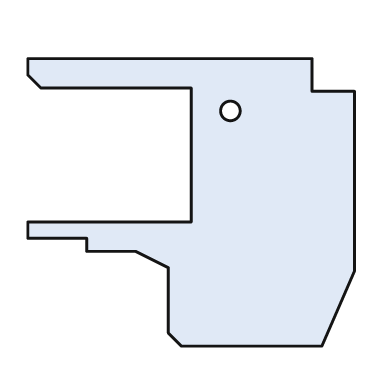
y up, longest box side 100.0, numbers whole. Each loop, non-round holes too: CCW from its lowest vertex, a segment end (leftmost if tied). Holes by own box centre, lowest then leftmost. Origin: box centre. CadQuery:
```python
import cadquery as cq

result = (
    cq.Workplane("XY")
    .moveTo(-3.0, -44.0)
    .lineTo(40.0, -44.0)
    .lineTo(50.0, -21.0)
    .lineTo(50.0, 34.0)
    .lineTo(37.0, 34.0)
    .lineTo(37.0, 44.0)
    .lineTo(-50.0, 44.0)
    .lineTo(-50.0, 39.0)
    .lineTo(-46.0, 35.0)
    .lineTo(0.0, 35.0)
    .lineTo(0.0, -6.0)
    .lineTo(-50.0, -6.0)
    .lineTo(-50.0, -11.0)
    .lineTo(-32.0, -11.0)
    .lineTo(-32.0, -15.0)
    .lineTo(-17.0, -15.0)
    .lineTo(-7.0, -20.0)
    .lineTo(-7.0, -40.0)
    .close()
    .moveTo(12.0, 28.0)
    .circle(3.0)
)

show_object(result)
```